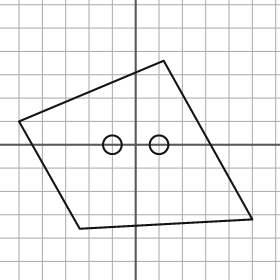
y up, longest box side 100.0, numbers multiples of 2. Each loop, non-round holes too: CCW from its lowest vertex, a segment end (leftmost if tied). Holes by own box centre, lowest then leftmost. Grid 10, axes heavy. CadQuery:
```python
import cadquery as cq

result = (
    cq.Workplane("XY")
    .moveTo(-24.0, -36.0)
    .lineTo(50.0, -32.0)
    .lineTo(12.0, 36.0)
    .lineTo(-50.0, 10.0)
    .close()
    .moveTo(-10.0, 0.0)
    .circle(4.0)
    .moveTo(10.0, 0.0)
    .circle(4.0)
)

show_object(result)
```